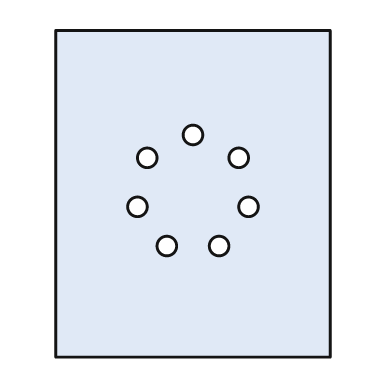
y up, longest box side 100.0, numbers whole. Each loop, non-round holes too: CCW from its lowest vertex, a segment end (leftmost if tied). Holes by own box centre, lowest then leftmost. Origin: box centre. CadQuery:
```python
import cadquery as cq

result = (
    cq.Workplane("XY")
    .moveTo(-42.0, -50.0)
    .lineTo(42.0, -50.0)
    .lineTo(42.0, 50.0)
    .lineTo(-42.0, 50.0)
    .close()
    .moveTo(-8.0, -16.0)
    .circle(3.0)
    .moveTo(8.0, -16.0)
    .circle(3.0)
    .moveTo(-17.0, -4.0)
    .circle(3.0)
    .moveTo(17.0, -4.0)
    .circle(3.0)
    .moveTo(-14.0, 11.0)
    .circle(3.0)
    .moveTo(14.0, 11.0)
    .circle(3.0)
    .moveTo(0.0, 18.0)
    .circle(3.0)
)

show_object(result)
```